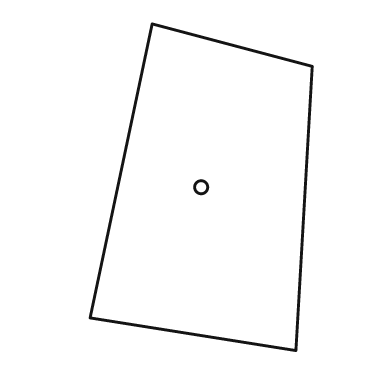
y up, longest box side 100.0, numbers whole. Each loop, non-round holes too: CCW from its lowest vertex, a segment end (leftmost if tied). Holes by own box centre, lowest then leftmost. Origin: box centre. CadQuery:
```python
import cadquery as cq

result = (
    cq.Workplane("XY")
    .moveTo(29.0, -50.0)
    .lineTo(34.0, 37.0)
    .lineTo(-15.0, 50.0)
    .lineTo(-34.0, -40.0)
    .close()
    .moveTo(0.0, 0.0)
    .circle(2.0)
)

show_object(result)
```